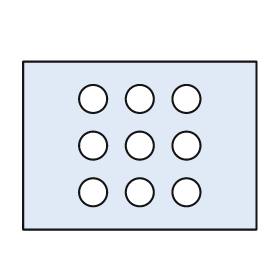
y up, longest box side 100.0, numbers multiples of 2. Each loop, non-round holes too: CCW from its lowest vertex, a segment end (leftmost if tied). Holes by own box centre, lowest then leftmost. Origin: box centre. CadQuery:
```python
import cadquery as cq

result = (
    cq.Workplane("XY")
    .moveTo(-50.0, -36.0)
    .lineTo(50.0, -36.0)
    .lineTo(50.0, 36.0)
    .lineTo(-50.0, 36.0)
    .close()
    .moveTo(-20.0, -20.0)
    .circle(6.0)
    .moveTo(0.0, -20.0)
    .circle(6.0)
    .moveTo(20.0, -20.0)
    .circle(6.0)
    .moveTo(-20.0, 0.0)
    .circle(6.0)
    .moveTo(0.0, 0.0)
    .circle(6.0)
    .moveTo(20.0, 0.0)
    .circle(6.0)
    .moveTo(-20.0, 20.0)
    .circle(6.0)
    .moveTo(0.0, 20.0)
    .circle(6.0)
    .moveTo(20.0, 20.0)
    .circle(6.0)
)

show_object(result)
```